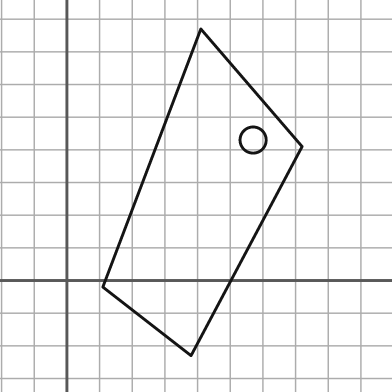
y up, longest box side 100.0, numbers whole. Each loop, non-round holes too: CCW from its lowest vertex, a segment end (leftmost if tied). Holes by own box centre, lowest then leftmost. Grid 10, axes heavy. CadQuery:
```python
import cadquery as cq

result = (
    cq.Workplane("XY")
    .moveTo(38.0, -23.0)
    .lineTo(72.0, 41.0)
    .lineTo(41.0, 77.0)
    .lineTo(11.0, -2.0)
    .close()
    .moveTo(57.0, 43.0)
    .circle(4.0)
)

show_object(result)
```